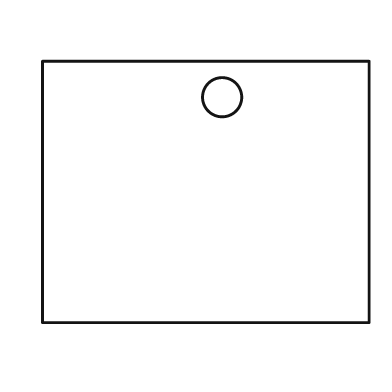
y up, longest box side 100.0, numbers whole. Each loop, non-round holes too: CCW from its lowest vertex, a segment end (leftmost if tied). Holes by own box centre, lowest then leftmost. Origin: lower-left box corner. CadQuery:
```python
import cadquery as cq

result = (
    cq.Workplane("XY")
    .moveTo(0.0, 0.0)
    .lineTo(100.0, 0.0)
    .lineTo(100.0, 80.0)
    .lineTo(0.0, 80.0)
    .close()
    .moveTo(55.0, 69.0)
    .circle(6.0)
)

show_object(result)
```